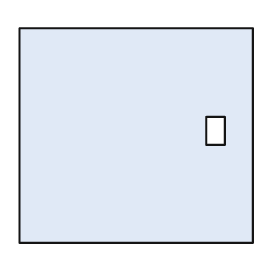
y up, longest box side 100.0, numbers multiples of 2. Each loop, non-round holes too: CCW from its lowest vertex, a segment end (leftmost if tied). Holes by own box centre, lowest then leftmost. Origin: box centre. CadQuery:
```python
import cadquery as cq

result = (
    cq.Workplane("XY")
    .moveTo(-50.0, -46.0)
    .lineTo(50.0, -46.0)
    .lineTo(50.0, 46.0)
    .lineTo(-50.0, 46.0)
    .close()
    .moveTo(30.0, -4.0)
    .lineTo(38.0, -4.0)
    .lineTo(38.0, 8.0)
    .lineTo(30.0, 8.0)
    .close()
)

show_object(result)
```